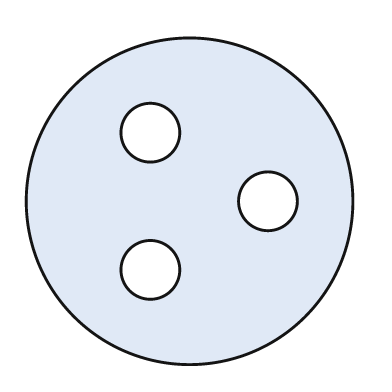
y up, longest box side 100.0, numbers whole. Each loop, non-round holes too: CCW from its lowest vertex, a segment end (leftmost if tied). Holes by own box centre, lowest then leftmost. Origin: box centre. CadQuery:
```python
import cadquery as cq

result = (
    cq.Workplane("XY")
    .moveTo(0.0, 0.0)
    .circle(50.0)
    .moveTo(-12.0, -21.0)
    .circle(9.0)
    .moveTo(24.0, 0.0)
    .circle(9.0)
    .moveTo(-12.0, 21.0)
    .circle(9.0)
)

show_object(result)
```